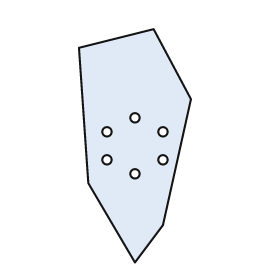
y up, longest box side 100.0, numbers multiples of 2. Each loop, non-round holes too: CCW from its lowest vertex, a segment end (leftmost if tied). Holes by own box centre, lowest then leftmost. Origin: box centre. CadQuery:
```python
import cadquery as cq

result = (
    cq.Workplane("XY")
    .moveTo(0.0, -50.0)
    .lineTo(12.0, -34.0)
    .lineTo(24.0, 20.0)
    .lineTo(8.0, 50.0)
    .lineTo(-24.0, 42.0)
    .lineTo(-20.0, -16.0)
    .close()
    .moveTo(0.0, -12.0)
    .circle(2.0)
    .moveTo(-12.0, -6.0)
    .circle(2.0)
    .moveTo(12.0, -6.0)
    .circle(2.0)
    .moveTo(-12.0, 6.0)
    .circle(2.0)
    .moveTo(12.0, 6.0)
    .circle(2.0)
    .moveTo(0.0, 12.0)
    .circle(2.0)
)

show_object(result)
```